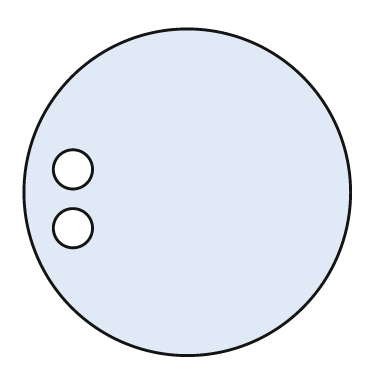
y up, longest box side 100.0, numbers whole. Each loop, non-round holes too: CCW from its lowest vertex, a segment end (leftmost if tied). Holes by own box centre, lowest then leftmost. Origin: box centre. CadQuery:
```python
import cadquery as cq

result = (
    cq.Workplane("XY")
    .moveTo(0.0, 0.0)
    .circle(50.0)
    .moveTo(-35.0, -11.0)
    .circle(6.0)
    .moveTo(-35.0, 7.0)
    .circle(6.0)
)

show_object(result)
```